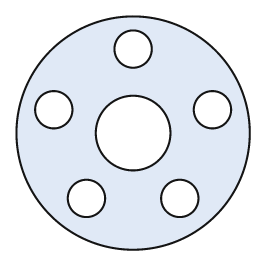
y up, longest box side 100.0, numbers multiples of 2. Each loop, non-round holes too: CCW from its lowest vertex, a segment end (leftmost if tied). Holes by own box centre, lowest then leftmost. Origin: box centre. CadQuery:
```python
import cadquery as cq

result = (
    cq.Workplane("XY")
    .moveTo(0.0, 0.0)
    .circle(50.0)
    .moveTo(-20.0, -28.0)
    .circle(8.0)
    .moveTo(20.0, -28.0)
    .circle(8.0)
    .moveTo(0.0, 0.0)
    .circle(16.0)
    .moveTo(-34.0, 10.0)
    .circle(8.0)
    .moveTo(34.0, 10.0)
    .circle(8.0)
    .moveTo(0.0, 36.0)
    .circle(8.0)
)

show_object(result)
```